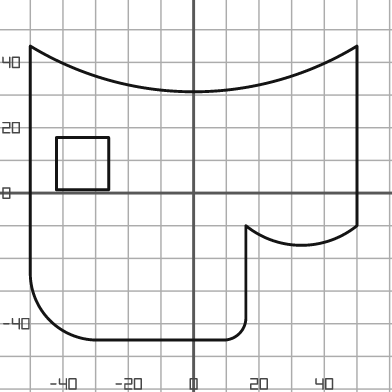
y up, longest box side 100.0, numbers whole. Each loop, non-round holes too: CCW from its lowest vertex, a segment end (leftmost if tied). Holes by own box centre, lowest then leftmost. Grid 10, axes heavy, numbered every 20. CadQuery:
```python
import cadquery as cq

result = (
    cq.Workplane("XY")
    .moveTo(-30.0, -45.0)
    .lineTo(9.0, -45.0)
    .threePointArc((14.0, -43.0), (16.0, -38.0))
    .lineTo(16.0, -10.0)
    .threePointArc((33.0, -16.0), (50.0, -10.0))
    .lineTo(50.0, 45.0)
    .threePointArc((0.0, 31.0), (-50.0, 45.0))
    .lineTo(-50.0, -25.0)
    .threePointArc((-44.0, -39.0), (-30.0, -45.0))
    .close()
    .moveTo(-42.0, 1.0)
    .lineTo(-26.0, 1.0)
    .lineTo(-26.0, 17.0)
    .lineTo(-42.0, 17.0)
    .close()
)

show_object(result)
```